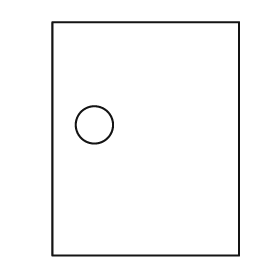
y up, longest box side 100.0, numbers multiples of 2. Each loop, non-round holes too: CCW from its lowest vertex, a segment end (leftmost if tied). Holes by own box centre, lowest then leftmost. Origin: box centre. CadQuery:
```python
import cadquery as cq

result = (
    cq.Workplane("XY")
    .moveTo(-40.0, -50.0)
    .lineTo(40.0, -50.0)
    .lineTo(40.0, 50.0)
    .lineTo(-40.0, 50.0)
    .close()
    .moveTo(-22.0, 6.0)
    .circle(8.0)
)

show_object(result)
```